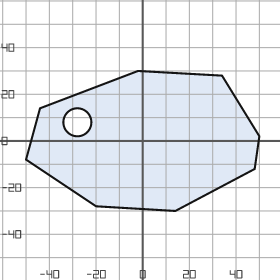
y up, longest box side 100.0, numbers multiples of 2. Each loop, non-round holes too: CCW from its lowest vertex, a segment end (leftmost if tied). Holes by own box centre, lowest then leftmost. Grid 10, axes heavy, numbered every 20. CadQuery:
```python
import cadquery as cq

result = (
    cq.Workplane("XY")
    .moveTo(14.0, -30.0)
    .lineTo(48.0, -12.0)
    .lineTo(50.0, 2.0)
    .lineTo(34.0, 28.0)
    .lineTo(-2.0, 30.0)
    .lineTo(-44.0, 14.0)
    .lineTo(-50.0, -8.0)
    .lineTo(-20.0, -28.0)
    .close()
    .moveTo(-28.0, 8.0)
    .circle(6.0)
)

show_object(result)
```